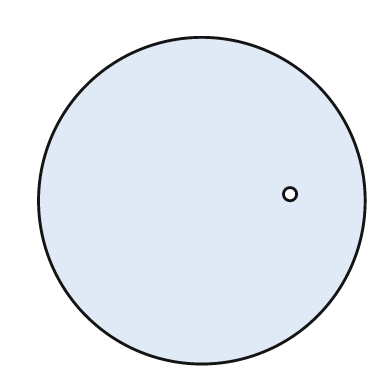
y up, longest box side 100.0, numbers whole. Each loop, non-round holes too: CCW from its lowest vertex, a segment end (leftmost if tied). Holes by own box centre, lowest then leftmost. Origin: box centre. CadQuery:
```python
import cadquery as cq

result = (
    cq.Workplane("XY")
    .moveTo(0.0, 0.0)
    .circle(50.0)
    .moveTo(27.0, 2.0)
    .circle(2.0)
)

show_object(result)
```